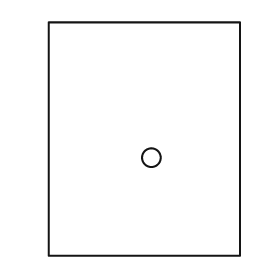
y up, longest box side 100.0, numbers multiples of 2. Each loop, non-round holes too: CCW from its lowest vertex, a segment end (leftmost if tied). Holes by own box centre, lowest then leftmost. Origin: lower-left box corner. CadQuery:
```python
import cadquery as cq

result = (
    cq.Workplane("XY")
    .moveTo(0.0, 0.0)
    .lineTo(82.0, 0.0)
    .lineTo(82.0, 100.0)
    .lineTo(0.0, 100.0)
    .close()
    .moveTo(44.0, 42.0)
    .circle(4.0)
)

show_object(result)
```